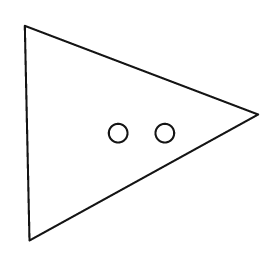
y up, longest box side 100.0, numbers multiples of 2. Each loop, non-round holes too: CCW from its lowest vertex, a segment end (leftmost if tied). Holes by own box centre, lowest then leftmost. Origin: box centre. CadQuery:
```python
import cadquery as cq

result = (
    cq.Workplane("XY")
    .moveTo(-48.0, -46.0)
    .lineTo(50.0, 8.0)
    .lineTo(-50.0, 46.0)
    .close()
    .moveTo(-10.0, 0.0)
    .circle(4.0)
    .moveTo(10.0, 0.0)
    .circle(4.0)
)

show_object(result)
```